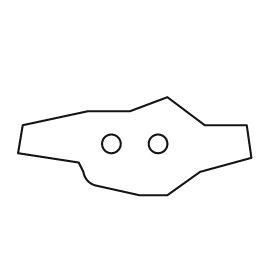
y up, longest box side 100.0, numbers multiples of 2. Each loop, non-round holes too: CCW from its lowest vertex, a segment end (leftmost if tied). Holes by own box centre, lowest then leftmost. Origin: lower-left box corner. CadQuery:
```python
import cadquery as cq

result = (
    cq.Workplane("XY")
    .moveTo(52.0, 0.0)
    .lineTo(64.0, 0.0)
    .lineTo(78.0, 10.0)
    .lineTo(100.0, 16.0)
    .lineTo(98.0, 30.0)
    .lineTo(80.0, 30.0)
    .lineTo(64.0, 42.0)
    .lineTo(48.0, 36.0)
    .lineTo(30.0, 36.0)
    .lineTo(2.0, 30.0)
    .lineTo(0.0, 18.0)
    .lineTo(26.0, 14.0)
    .lineTo(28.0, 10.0)
    .threePointArc((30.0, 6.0), (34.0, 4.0))
    .close()
    .moveTo(40.0, 22.0)
    .circle(4.0)
    .moveTo(60.0, 22.0)
    .circle(4.0)
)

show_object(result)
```